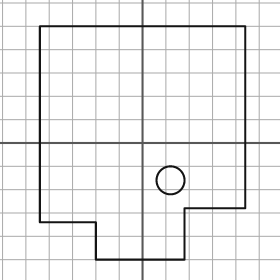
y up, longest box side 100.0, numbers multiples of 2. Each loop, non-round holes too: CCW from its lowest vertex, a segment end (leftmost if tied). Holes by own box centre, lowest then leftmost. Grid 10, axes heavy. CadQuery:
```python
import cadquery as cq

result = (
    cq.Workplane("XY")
    .moveTo(-20.0, -50.0)
    .lineTo(18.0, -50.0)
    .lineTo(18.0, -28.0)
    .lineTo(44.0, -28.0)
    .lineTo(44.0, 50.0)
    .lineTo(-44.0, 50.0)
    .lineTo(-44.0, -34.0)
    .lineTo(-20.0, -34.0)
    .close()
    .moveTo(12.0, -16.0)
    .circle(6.0)
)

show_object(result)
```